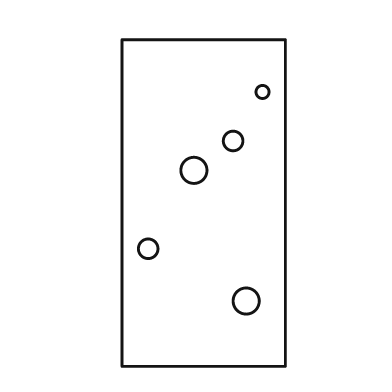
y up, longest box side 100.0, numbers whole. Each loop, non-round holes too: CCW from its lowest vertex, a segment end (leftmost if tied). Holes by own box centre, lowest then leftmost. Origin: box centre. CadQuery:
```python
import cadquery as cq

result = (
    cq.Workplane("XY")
    .moveTo(-25.0, -50.0)
    .lineTo(25.0, -50.0)
    .lineTo(25.0, 50.0)
    .lineTo(-25.0, 50.0)
    .close()
    .moveTo(13.0, -30.0)
    .circle(4.0)
    .moveTo(-17.0, -14.0)
    .circle(3.0)
    .moveTo(-3.0, 10.0)
    .circle(4.0)
    .moveTo(9.0, 19.0)
    .circle(3.0)
    .moveTo(18.0, 34.0)
    .circle(2.0)
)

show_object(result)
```